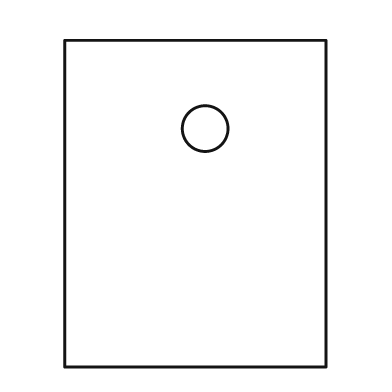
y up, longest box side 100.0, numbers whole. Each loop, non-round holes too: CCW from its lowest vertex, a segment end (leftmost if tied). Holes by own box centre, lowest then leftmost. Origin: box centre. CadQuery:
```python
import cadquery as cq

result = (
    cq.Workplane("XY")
    .moveTo(-40.0, -50.0)
    .lineTo(40.0, -50.0)
    .lineTo(40.0, 50.0)
    .lineTo(-40.0, 50.0)
    .close()
    .moveTo(3.0, 23.0)
    .circle(7.0)
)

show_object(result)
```